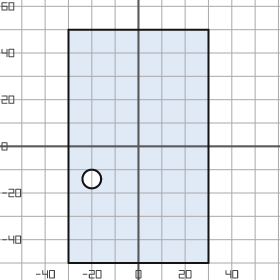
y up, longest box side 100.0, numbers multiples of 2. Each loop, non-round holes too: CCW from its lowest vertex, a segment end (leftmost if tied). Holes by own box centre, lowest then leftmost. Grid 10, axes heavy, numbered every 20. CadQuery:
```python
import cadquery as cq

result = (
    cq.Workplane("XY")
    .moveTo(-30.0, -50.0)
    .lineTo(30.0, -50.0)
    .lineTo(30.0, 50.0)
    .lineTo(-30.0, 50.0)
    .close()
    .moveTo(-20.0, -14.0)
    .circle(4.0)
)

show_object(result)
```